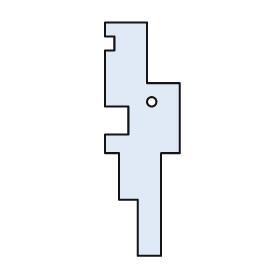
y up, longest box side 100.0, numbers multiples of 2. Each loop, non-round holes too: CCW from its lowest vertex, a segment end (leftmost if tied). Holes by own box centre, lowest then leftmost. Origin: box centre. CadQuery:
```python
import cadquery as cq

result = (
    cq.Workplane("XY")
    .moveTo(-2.0, -50.0)
    .lineTo(8.0, -50.0)
    .lineTo(8.0, -6.0)
    .lineTo(16.0, -6.0)
    .lineTo(16.0, 24.0)
    .lineTo(2.0, 24.0)
    .lineTo(2.0, 50.0)
    .lineTo(-16.0, 50.0)
    .lineTo(-16.0, 44.0)
    .lineTo(-12.0, 44.0)
    .lineTo(-12.0, 38.0)
    .lineTo(-16.0, 38.0)
    .lineTo(-16.0, 14.0)
    .lineTo(-6.0, 14.0)
    .lineTo(-6.0, 2.0)
    .lineTo(-16.0, 2.0)
    .lineTo(-16.0, -6.0)
    .lineTo(-10.0, -6.0)
    .lineTo(-10.0, -26.0)
    .lineTo(-2.0, -26.0)
    .close()
    .moveTo(4.0, 16.0)
    .circle(2.0)
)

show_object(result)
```